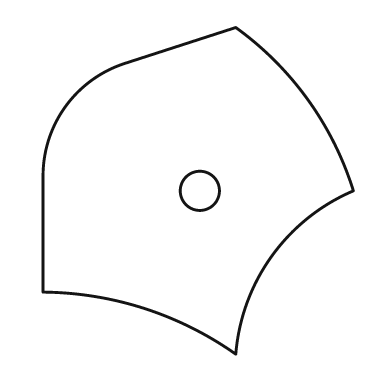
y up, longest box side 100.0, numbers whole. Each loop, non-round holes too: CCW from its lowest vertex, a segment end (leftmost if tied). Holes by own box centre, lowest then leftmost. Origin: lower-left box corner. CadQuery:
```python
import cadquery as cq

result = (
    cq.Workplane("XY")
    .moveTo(59.0, 0.0)
    .threePointArc((70.0, 30.0), (95.0, 50.0))
    .threePointArc((81.0, 78.0), (59.0, 100.0))
    .lineTo(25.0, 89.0)
    .threePointArc((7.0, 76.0), (0.0, 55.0))
    .lineTo(0.0, 19.0)
    .threePointArc((31.0, 14.0), (59.0, 0.0))
    .close()
    .moveTo(48.0, 50.0)
    .circle(6.0)
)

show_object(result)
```